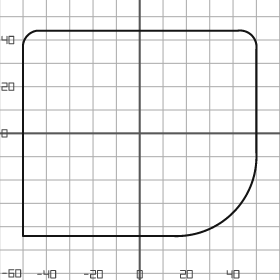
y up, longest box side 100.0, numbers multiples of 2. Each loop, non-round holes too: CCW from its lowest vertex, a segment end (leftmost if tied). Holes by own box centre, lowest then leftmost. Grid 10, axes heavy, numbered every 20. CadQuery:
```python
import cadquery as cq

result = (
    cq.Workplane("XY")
    .moveTo(-50.0, -44.0)
    .lineTo(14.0, -44.0)
    .threePointArc((40.0, -34.0), (50.0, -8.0))
    .lineTo(50.0, 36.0)
    .threePointArc((48.0, 42.0), (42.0, 44.0))
    .lineTo(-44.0, 44.0)
    .threePointArc((-48.0, 42.0), (-50.0, 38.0))
    .close()
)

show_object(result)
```